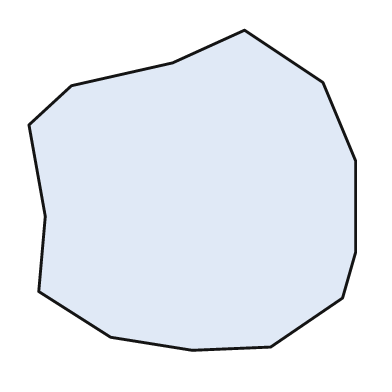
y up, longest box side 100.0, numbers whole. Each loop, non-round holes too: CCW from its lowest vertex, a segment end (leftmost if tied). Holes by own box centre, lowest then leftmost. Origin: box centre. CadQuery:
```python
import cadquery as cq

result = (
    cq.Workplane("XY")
    .moveTo(0.0, -49.0)
    .lineTo(24.0, -48.0)
    .lineTo(46.0, -33.0)
    .lineTo(50.0, -19.0)
    .lineTo(50.0, 9.0)
    .lineTo(40.0, 33.0)
    .lineTo(16.0, 49.0)
    .lineTo(-6.0, 39.0)
    .lineTo(-37.0, 32.0)
    .lineTo(-50.0, 20.0)
    .lineTo(-45.0, -8.0)
    .lineTo(-47.0, -31.0)
    .lineTo(-25.0, -45.0)
    .close()
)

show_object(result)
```